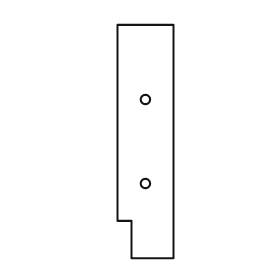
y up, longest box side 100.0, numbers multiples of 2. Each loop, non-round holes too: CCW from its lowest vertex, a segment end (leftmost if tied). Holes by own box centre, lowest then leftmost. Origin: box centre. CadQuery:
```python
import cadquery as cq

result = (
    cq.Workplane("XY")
    .moveTo(-6.0, -50.0)
    .lineTo(12.0, -50.0)
    .lineTo(12.0, 50.0)
    .lineTo(-12.0, 50.0)
    .lineTo(-12.0, -34.0)
    .lineTo(-6.0, -34.0)
    .close()
    .moveTo(0.0, -18.0)
    .circle(2.0)
    .moveTo(0.0, 18.0)
    .circle(2.0)
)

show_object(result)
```